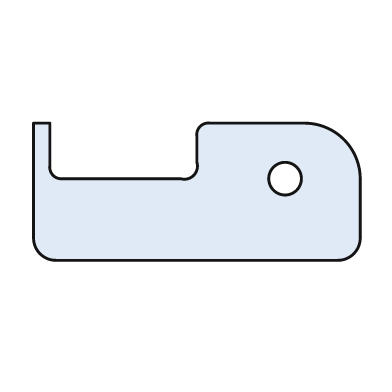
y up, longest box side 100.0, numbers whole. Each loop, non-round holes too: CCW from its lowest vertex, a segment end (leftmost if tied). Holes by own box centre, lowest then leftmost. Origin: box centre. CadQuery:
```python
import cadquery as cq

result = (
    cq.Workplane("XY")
    .moveTo(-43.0, -21.0)
    .lineTo(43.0, -21.0)
    .threePointArc((48.0, -19.0), (50.0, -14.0))
    .lineTo(50.0, 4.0)
    .threePointArc((45.0, 16.0), (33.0, 21.0))
    .lineTo(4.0, 21.0)
    .threePointArc((1.0, 20.0), (0.0, 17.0))
    .lineTo(0.0, 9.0)
    .threePointArc((-1.0, 5.0), (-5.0, 4.0))
    .lineTo(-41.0, 4.0)
    .threePointArc((-44.0, 5.0), (-45.0, 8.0))
    .lineTo(-45.0, 21.0)
    .lineTo(-50.0, 21.0)
    .lineTo(-50.0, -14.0)
    .threePointArc((-48.0, -19.0), (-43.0, -21.0))
    .close()
    .moveTo(27.0, 4.0)
    .circle(5.0)
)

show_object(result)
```